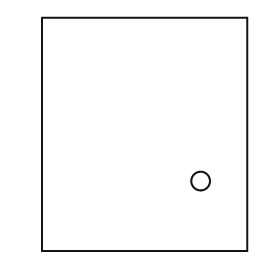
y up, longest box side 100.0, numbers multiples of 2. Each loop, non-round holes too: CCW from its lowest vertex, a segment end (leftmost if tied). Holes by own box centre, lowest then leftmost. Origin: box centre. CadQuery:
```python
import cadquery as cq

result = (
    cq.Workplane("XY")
    .moveTo(-44.0, -50.0)
    .lineTo(44.0, -50.0)
    .lineTo(44.0, 50.0)
    .lineTo(-44.0, 50.0)
    .close()
    .moveTo(24.0, -20.0)
    .circle(4.0)
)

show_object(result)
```